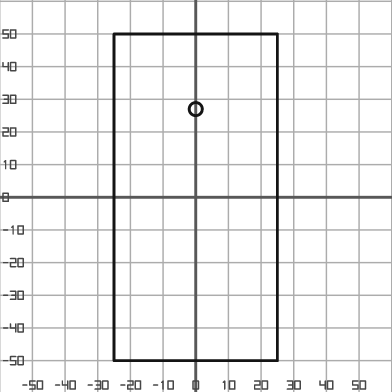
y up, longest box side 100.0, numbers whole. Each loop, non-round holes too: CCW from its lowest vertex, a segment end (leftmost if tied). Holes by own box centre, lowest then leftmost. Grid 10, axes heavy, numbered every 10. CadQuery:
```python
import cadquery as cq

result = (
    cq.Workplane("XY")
    .moveTo(-25.0, -50.0)
    .lineTo(25.0, -50.0)
    .lineTo(25.0, 50.0)
    .lineTo(-25.0, 50.0)
    .close()
    .moveTo(0.0, 27.0)
    .circle(2.0)
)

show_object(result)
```